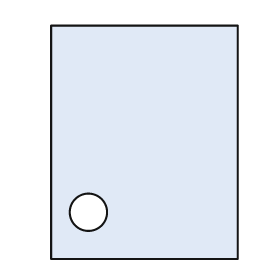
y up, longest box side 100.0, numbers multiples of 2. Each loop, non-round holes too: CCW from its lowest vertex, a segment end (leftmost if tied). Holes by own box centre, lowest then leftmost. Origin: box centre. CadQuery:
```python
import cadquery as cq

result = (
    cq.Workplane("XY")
    .moveTo(-40.0, -50.0)
    .lineTo(40.0, -50.0)
    .lineTo(40.0, 50.0)
    .lineTo(-40.0, 50.0)
    .close()
    .moveTo(-24.0, -30.0)
    .circle(8.0)
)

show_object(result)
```